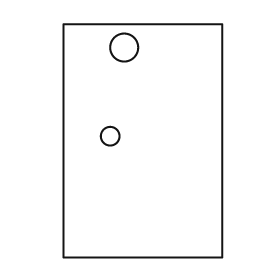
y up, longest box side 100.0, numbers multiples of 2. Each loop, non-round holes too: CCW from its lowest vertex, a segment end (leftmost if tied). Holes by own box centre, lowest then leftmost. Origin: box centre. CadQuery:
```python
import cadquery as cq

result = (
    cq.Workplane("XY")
    .moveTo(-34.0, -50.0)
    .lineTo(34.0, -50.0)
    .lineTo(34.0, 50.0)
    .lineTo(-34.0, 50.0)
    .close()
    .moveTo(-14.0, 2.0)
    .circle(4.0)
    .moveTo(-8.0, 40.0)
    .circle(6.0)
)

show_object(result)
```